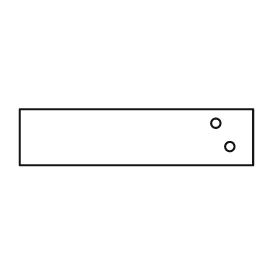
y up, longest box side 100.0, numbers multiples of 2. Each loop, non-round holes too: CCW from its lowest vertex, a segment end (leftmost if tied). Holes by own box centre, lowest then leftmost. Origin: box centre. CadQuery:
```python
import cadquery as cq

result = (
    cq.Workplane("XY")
    .moveTo(-50.0, -12.0)
    .lineTo(50.0, -12.0)
    .lineTo(50.0, 12.0)
    .lineTo(-50.0, 12.0)
    .close()
    .moveTo(40.0, -4.0)
    .circle(2.0)
    .moveTo(34.0, 6.0)
    .circle(2.0)
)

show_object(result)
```